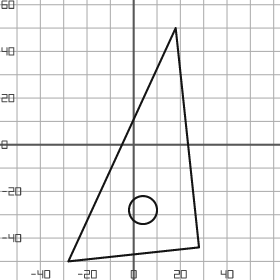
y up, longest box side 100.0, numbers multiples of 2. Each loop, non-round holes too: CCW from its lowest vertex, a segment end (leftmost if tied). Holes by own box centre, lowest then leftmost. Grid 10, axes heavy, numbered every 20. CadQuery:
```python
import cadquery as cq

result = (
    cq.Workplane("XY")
    .moveTo(-28.0, -50.0)
    .lineTo(28.0, -44.0)
    .lineTo(18.0, 50.0)
    .close()
    .moveTo(4.0, -28.0)
    .circle(6.0)
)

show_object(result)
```